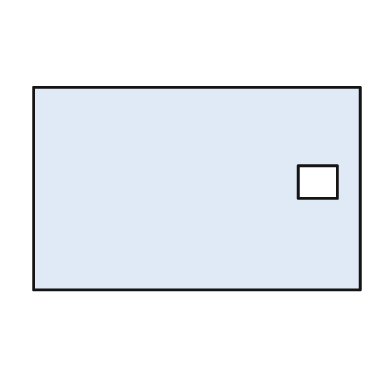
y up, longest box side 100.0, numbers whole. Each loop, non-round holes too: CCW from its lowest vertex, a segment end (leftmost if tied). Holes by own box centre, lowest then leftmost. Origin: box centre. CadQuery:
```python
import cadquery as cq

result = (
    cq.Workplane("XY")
    .moveTo(-50.0, -31.0)
    .lineTo(50.0, -31.0)
    .lineTo(50.0, 31.0)
    .lineTo(-50.0, 31.0)
    .close()
    .moveTo(31.0, -3.0)
    .lineTo(43.0, -3.0)
    .lineTo(43.0, 7.0)
    .lineTo(31.0, 7.0)
    .close()
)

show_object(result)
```